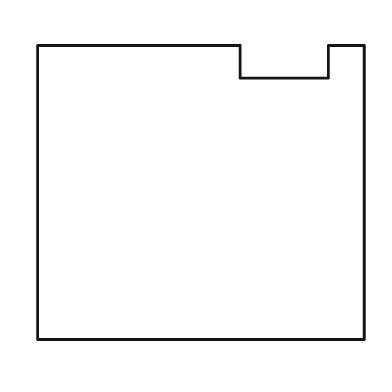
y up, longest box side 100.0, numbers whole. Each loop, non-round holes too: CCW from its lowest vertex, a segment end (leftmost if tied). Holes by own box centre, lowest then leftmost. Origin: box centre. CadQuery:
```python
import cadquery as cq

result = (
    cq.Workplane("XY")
    .moveTo(-50.0, -45.0)
    .lineTo(50.0, -45.0)
    .lineTo(50.0, 45.0)
    .lineTo(39.0, 45.0)
    .lineTo(39.0, 35.0)
    .lineTo(12.0, 35.0)
    .lineTo(12.0, 45.0)
    .lineTo(-50.0, 45.0)
    .close()
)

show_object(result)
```